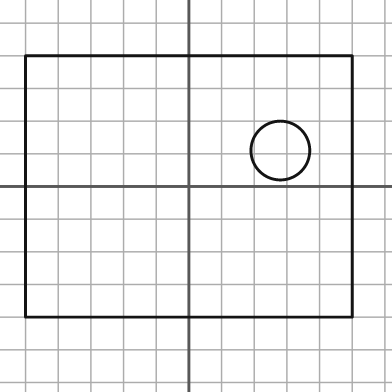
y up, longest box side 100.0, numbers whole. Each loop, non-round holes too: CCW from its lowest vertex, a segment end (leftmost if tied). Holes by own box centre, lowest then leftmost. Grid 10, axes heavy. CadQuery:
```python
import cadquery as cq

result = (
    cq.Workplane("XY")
    .moveTo(-50.0, -40.0)
    .lineTo(50.0, -40.0)
    .lineTo(50.0, 40.0)
    .lineTo(-50.0, 40.0)
    .close()
    .moveTo(28.0, 11.0)
    .circle(9.0)
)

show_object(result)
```